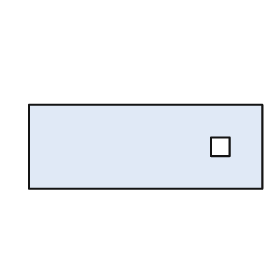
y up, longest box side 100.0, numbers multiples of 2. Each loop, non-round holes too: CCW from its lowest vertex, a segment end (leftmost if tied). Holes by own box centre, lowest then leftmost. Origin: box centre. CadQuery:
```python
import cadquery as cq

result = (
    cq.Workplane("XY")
    .moveTo(-50.0, -18.0)
    .lineTo(50.0, -18.0)
    .lineTo(50.0, 18.0)
    .lineTo(-50.0, 18.0)
    .close()
    .moveTo(28.0, -4.0)
    .lineTo(36.0, -4.0)
    .lineTo(36.0, 4.0)
    .lineTo(28.0, 4.0)
    .close()
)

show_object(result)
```